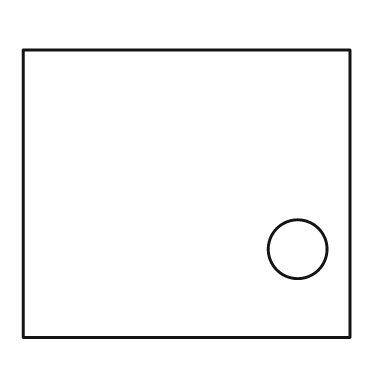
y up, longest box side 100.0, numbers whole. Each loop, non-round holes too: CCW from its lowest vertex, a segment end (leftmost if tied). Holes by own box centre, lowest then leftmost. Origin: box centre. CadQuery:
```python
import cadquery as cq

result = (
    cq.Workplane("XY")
    .moveTo(-50.0, -44.0)
    .lineTo(50.0, -44.0)
    .lineTo(50.0, 44.0)
    .lineTo(-50.0, 44.0)
    .close()
    .moveTo(34.0, -17.0)
    .circle(9.0)
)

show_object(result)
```